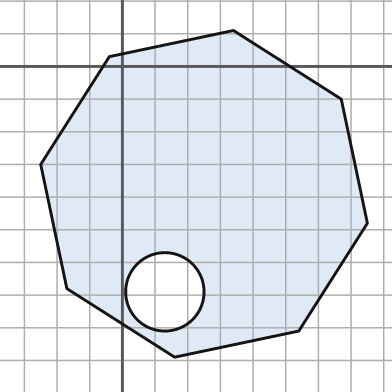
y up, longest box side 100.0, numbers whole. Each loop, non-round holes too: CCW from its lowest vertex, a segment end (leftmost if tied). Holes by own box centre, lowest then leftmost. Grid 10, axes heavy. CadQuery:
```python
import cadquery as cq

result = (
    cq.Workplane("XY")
    .moveTo(16.0, -89.0)
    .lineTo(54.0, -81.0)
    .lineTo(75.0, -48.0)
    .lineTo(67.0, -10.0)
    .lineTo(34.0, 11.0)
    .lineTo(-4.0, 3.0)
    .lineTo(-25.0, -30.0)
    .lineTo(-17.0, -68.0)
    .close()
    .moveTo(13.0, -69.0)
    .circle(12.0)
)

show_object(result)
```